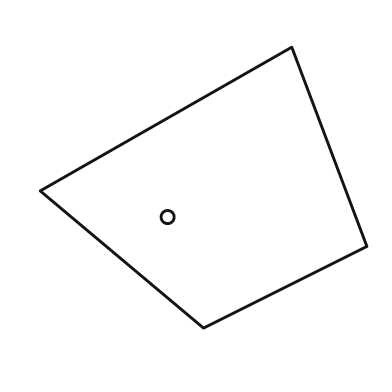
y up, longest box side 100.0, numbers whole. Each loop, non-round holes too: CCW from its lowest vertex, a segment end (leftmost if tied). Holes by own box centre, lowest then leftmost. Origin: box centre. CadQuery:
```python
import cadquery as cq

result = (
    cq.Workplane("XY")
    .moveTo(0.0, -43.0)
    .lineTo(50.0, -18.0)
    .lineTo(27.0, 43.0)
    .lineTo(-50.0, -1.0)
    .close()
    .moveTo(-11.0, -9.0)
    .circle(2.0)
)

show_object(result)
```